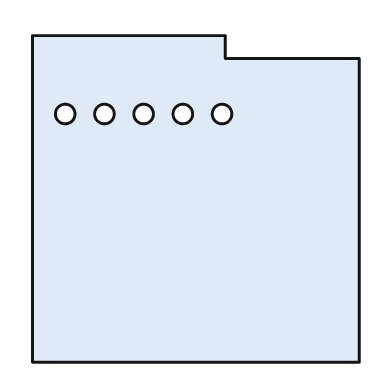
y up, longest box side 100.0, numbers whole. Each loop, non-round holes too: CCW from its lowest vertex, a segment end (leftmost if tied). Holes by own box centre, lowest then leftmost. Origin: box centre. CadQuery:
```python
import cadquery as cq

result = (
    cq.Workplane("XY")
    .moveTo(-50.0, -50.0)
    .lineTo(50.0, -50.0)
    .lineTo(50.0, 43.0)
    .lineTo(9.0, 43.0)
    .lineTo(9.0, 50.0)
    .lineTo(-50.0, 50.0)
    .close()
    .moveTo(-40.0, 26.0)
    .circle(3.0)
    .moveTo(-28.0, 26.0)
    .circle(3.0)
    .moveTo(-16.0, 26.0)
    .circle(3.0)
    .moveTo(-4.0, 26.0)
    .circle(3.0)
    .moveTo(8.0, 26.0)
    .circle(3.0)
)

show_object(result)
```